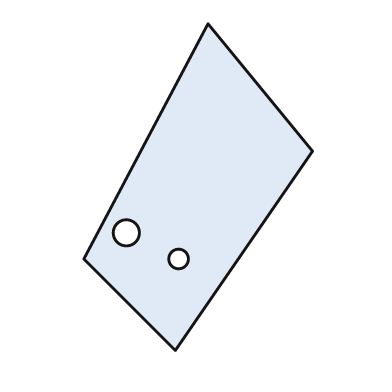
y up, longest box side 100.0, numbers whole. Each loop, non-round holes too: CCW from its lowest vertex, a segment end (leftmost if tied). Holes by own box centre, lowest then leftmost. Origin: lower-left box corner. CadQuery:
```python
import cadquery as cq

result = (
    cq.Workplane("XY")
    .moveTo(28.0, 0.0)
    .lineTo(70.0, 61.0)
    .lineTo(38.0, 100.0)
    .lineTo(0.0, 28.0)
    .close()
    .moveTo(29.0, 28.0)
    .circle(3.0)
    .moveTo(13.0, 36.0)
    .circle(4.0)
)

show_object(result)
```